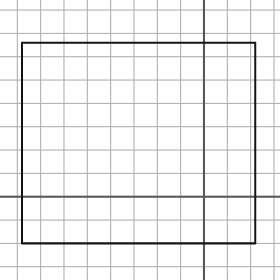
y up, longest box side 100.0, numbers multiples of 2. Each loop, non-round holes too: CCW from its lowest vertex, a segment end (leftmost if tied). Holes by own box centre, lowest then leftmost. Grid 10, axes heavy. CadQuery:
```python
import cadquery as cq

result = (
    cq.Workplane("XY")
    .moveTo(-78.0, -20.0)
    .lineTo(22.0, -20.0)
    .lineTo(22.0, 66.0)
    .lineTo(-78.0, 66.0)
    .close()
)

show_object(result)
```